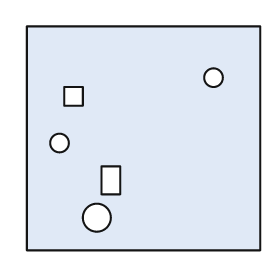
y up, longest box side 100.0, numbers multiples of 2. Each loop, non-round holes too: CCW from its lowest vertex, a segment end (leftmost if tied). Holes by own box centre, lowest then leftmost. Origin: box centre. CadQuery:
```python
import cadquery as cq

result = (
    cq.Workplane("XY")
    .moveTo(-50.0, -48.0)
    .lineTo(50.0, -48.0)
    .lineTo(50.0, 48.0)
    .lineTo(-50.0, 48.0)
    .close()
    .moveTo(-20.0, -34.0)
    .circle(6.0)
    .moveTo(-18.0, -24.0)
    .lineTo(-10.0, -24.0)
    .lineTo(-10.0, -12.0)
    .lineTo(-18.0, -12.0)
    .close()
    .moveTo(-36.0, -2.0)
    .circle(4.0)
    .moveTo(-34.0, 14.0)
    .lineTo(-26.0, 14.0)
    .lineTo(-26.0, 22.0)
    .lineTo(-34.0, 22.0)
    .close()
    .moveTo(30.0, 26.0)
    .circle(4.0)
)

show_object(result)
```